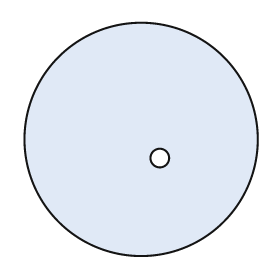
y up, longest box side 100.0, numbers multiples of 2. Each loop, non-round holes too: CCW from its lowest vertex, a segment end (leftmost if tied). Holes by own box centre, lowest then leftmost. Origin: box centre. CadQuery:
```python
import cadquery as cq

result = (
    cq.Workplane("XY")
    .moveTo(0.0, 0.0)
    .circle(50.0)
    .moveTo(8.0, -8.0)
    .circle(4.0)
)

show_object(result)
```